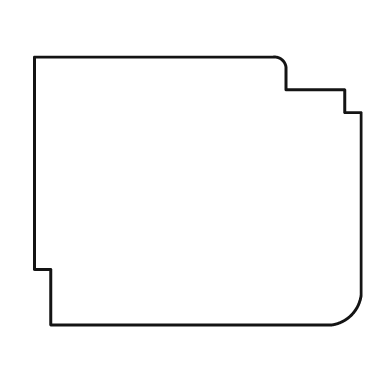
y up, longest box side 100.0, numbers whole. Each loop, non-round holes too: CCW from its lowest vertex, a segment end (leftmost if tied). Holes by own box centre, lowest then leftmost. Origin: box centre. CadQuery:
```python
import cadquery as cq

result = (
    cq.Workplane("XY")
    .moveTo(-45.0, -41.0)
    .lineTo(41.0, -41.0)
    .threePointArc((47.0, -38.0), (50.0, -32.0))
    .lineTo(50.0, 24.0)
    .lineTo(45.0, 24.0)
    .lineTo(45.0, 31.0)
    .lineTo(27.0, 31.0)
    .lineTo(27.0, 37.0)
    .threePointArc((26.0, 40.0), (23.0, 41.0))
    .lineTo(-50.0, 41.0)
    .lineTo(-50.0, -24.0)
    .lineTo(-45.0, -24.0)
    .close()
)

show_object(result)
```